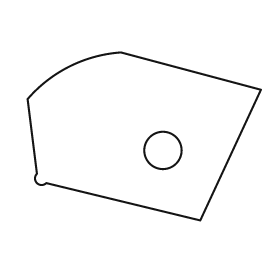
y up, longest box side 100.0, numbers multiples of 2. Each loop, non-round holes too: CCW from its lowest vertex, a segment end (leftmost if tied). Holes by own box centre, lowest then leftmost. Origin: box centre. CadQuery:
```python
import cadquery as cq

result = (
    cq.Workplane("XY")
    .moveTo(24.0, -36.0)
    .lineTo(50.0, 20.0)
    .lineTo(-10.0, 36.0)
    .threePointArc((-32.0, 30.0), (-50.0, 16.0))
    .lineTo(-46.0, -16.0)
    .threePointArc((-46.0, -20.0), (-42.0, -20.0))
    .close()
    .moveTo(8.0, -6.0)
    .circle(8.0)
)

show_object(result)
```